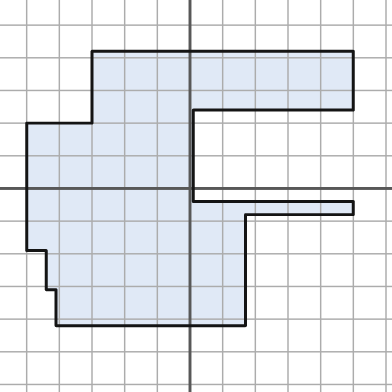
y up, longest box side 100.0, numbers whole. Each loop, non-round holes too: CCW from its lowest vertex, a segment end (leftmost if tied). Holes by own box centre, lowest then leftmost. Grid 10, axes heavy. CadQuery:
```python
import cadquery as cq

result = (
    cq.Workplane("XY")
    .moveTo(-41.0, -42.0)
    .lineTo(17.0, -42.0)
    .lineTo(17.0, -8.0)
    .lineTo(50.0, -8.0)
    .lineTo(50.0, -4.0)
    .lineTo(1.0, -4.0)
    .lineTo(1.0, 24.0)
    .lineTo(50.0, 24.0)
    .lineTo(50.0, 42.0)
    .lineTo(-30.0, 42.0)
    .lineTo(-30.0, 20.0)
    .lineTo(-50.0, 20.0)
    .lineTo(-50.0, -19.0)
    .lineTo(-44.0, -19.0)
    .lineTo(-44.0, -31.0)
    .lineTo(-41.0, -31.0)
    .close()
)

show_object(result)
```